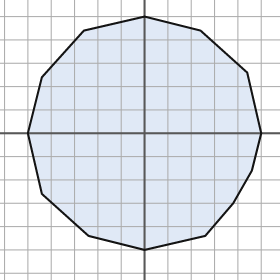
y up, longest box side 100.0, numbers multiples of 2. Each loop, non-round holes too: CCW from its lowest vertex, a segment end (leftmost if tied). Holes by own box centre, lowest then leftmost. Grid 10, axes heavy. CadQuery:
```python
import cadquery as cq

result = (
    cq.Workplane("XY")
    .moveTo(0.0, -50.0)
    .lineTo(26.0, -44.0)
    .lineTo(38.0, -30.0)
    .lineTo(46.0, -16.0)
    .lineTo(50.0, 0.0)
    .lineTo(44.0, 26.0)
    .lineTo(24.0, 44.0)
    .lineTo(0.0, 50.0)
    .lineTo(-26.0, 44.0)
    .lineTo(-44.0, 24.0)
    .lineTo(-50.0, 0.0)
    .lineTo(-44.0, -26.0)
    .lineTo(-24.0, -44.0)
    .close()
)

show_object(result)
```